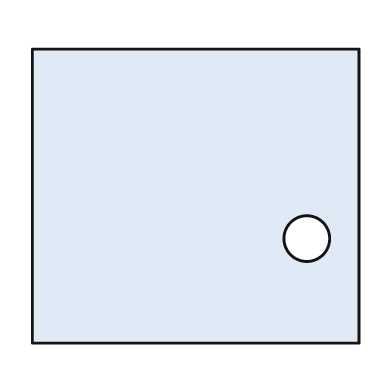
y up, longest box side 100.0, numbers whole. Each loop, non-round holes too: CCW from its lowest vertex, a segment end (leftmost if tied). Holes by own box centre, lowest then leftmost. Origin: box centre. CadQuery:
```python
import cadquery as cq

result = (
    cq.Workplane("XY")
    .moveTo(-50.0, -45.0)
    .lineTo(50.0, -45.0)
    .lineTo(50.0, 45.0)
    .lineTo(-50.0, 45.0)
    .close()
    .moveTo(34.0, -13.0)
    .circle(7.0)
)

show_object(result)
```